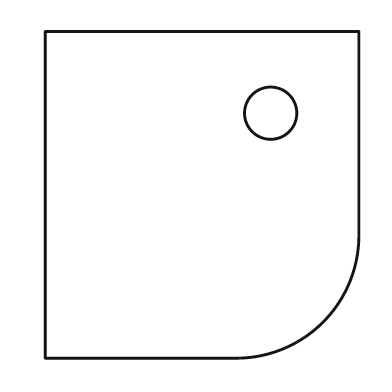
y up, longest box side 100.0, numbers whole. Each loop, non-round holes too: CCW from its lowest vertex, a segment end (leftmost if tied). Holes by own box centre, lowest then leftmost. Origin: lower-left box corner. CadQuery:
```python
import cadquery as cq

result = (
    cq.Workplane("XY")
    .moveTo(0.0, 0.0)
    .lineTo(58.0, 0.0)
    .threePointArc((85.0, 11.0), (96.0, 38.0))
    .lineTo(96.0, 100.0)
    .lineTo(0.0, 100.0)
    .close()
    .moveTo(69.0, 75.0)
    .circle(8.0)
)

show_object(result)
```